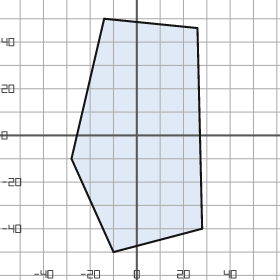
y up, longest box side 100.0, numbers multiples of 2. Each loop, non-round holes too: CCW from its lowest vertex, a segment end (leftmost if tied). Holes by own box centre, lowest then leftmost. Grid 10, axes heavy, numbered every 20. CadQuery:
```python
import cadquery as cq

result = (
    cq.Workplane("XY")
    .moveTo(-10.0, -50.0)
    .lineTo(28.0, -40.0)
    .lineTo(26.0, 46.0)
    .lineTo(-14.0, 50.0)
    .lineTo(-28.0, -10.0)
    .close()
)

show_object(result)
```